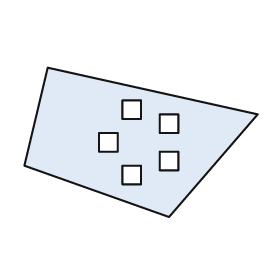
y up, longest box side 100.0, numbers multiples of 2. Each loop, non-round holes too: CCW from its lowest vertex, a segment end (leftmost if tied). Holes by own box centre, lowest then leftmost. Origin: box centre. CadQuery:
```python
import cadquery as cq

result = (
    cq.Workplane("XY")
    .moveTo(12.0, -32.0)
    .lineTo(50.0, 12.0)
    .lineTo(-40.0, 32.0)
    .lineTo(-50.0, -10.0)
    .close()
    .moveTo(-8.0, -18.0)
    .lineTo(0.0, -18.0)
    .lineTo(0.0, -10.0)
    .lineTo(-8.0, -10.0)
    .close()
    .moveTo(8.0, -12.0)
    .lineTo(16.0, -12.0)
    .lineTo(16.0, -4.0)
    .lineTo(8.0, -4.0)
    .close()
    .moveTo(-18.0, -4.0)
    .lineTo(-10.0, -4.0)
    .lineTo(-10.0, 4.0)
    .lineTo(-18.0, 4.0)
    .close()
    .moveTo(8.0, 4.0)
    .lineTo(16.0, 4.0)
    .lineTo(16.0, 12.0)
    .lineTo(8.0, 12.0)
    .close()
    .moveTo(-8.0, 10.0)
    .lineTo(0.0, 10.0)
    .lineTo(0.0, 18.0)
    .lineTo(-8.0, 18.0)
    .close()
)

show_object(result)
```